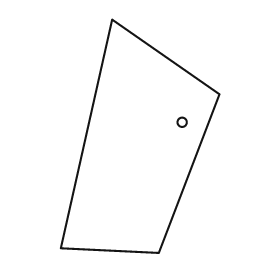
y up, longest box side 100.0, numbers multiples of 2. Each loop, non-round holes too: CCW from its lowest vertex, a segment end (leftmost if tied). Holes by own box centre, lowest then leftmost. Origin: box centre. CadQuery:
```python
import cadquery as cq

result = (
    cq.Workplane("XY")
    .moveTo(8.0, -50.0)
    .lineTo(34.0, 18.0)
    .lineTo(-12.0, 50.0)
    .lineTo(-34.0, -48.0)
    .close()
    .moveTo(18.0, 6.0)
    .circle(2.0)
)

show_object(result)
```